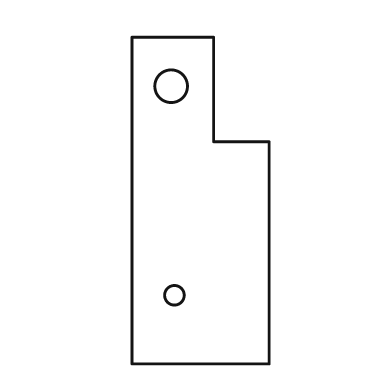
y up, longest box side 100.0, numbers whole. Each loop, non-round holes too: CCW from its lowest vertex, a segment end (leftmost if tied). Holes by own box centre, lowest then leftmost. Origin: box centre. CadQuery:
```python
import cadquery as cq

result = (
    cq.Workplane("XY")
    .moveTo(-21.0, -50.0)
    .lineTo(21.0, -50.0)
    .lineTo(21.0, 18.0)
    .lineTo(4.0, 18.0)
    .lineTo(4.0, 50.0)
    .lineTo(-21.0, 50.0)
    .close()
    .moveTo(-8.0, -29.0)
    .circle(3.0)
    .moveTo(-9.0, 35.0)
    .circle(5.0)
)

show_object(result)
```